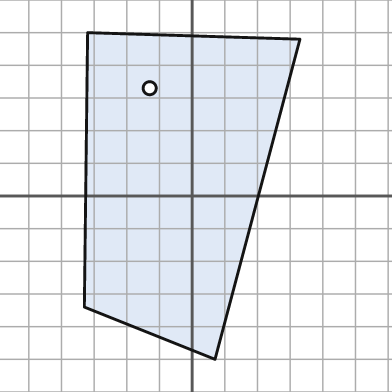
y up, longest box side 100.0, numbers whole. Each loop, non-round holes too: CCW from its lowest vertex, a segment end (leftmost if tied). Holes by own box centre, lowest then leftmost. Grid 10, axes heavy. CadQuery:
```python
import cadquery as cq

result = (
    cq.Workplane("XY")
    .moveTo(7.0, -50.0)
    .lineTo(33.0, 48.0)
    .lineTo(-32.0, 50.0)
    .lineTo(-33.0, -34.0)
    .close()
    .moveTo(-13.0, 33.0)
    .circle(2.0)
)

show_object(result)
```